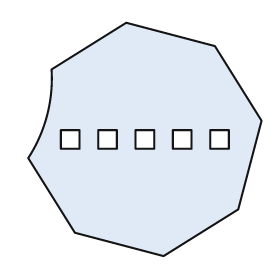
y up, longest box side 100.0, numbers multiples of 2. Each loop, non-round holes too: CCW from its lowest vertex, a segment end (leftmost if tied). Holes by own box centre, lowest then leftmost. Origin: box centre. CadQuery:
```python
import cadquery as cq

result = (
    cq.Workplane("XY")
    .moveTo(8.0, -50.0)
    .lineTo(40.0, -30.0)
    .lineTo(50.0, 8.0)
    .lineTo(30.0, 40.0)
    .lineTo(-8.0, 50.0)
    .lineTo(-40.0, 30.0)
    .threePointArc((-42.0, 10.0), (-50.0, -8.0))
    .lineTo(-30.0, -40.0)
    .close()
    .moveTo(-36.0, -4.0)
    .lineTo(-28.0, -4.0)
    .lineTo(-28.0, 4.0)
    .lineTo(-36.0, 4.0)
    .close()
    .moveTo(-20.0, -4.0)
    .lineTo(-12.0, -4.0)
    .lineTo(-12.0, 4.0)
    .lineTo(-20.0, 4.0)
    .close()
    .moveTo(-4.0, -4.0)
    .lineTo(4.0, -4.0)
    .lineTo(4.0, 4.0)
    .lineTo(-4.0, 4.0)
    .close()
    .moveTo(12.0, -4.0)
    .lineTo(20.0, -4.0)
    .lineTo(20.0, 4.0)
    .lineTo(12.0, 4.0)
    .close()
    .moveTo(28.0, -4.0)
    .lineTo(36.0, -4.0)
    .lineTo(36.0, 4.0)
    .lineTo(28.0, 4.0)
    .close()
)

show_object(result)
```